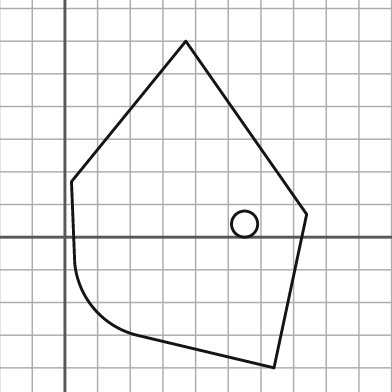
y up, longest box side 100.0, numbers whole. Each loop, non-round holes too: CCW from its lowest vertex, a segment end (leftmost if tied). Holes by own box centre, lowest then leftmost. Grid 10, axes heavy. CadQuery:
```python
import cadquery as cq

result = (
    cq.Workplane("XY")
    .moveTo(64.0, -40.0)
    .lineTo(74.0, 7.0)
    .lineTo(37.0, 60.0)
    .lineTo(2.0, 17.0)
    .lineTo(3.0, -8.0)
    .threePointArc((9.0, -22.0), (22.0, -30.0))
    .close()
    .moveTo(55.0, 4.0)
    .circle(4.0)
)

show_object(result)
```